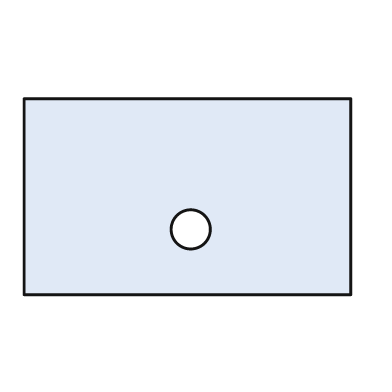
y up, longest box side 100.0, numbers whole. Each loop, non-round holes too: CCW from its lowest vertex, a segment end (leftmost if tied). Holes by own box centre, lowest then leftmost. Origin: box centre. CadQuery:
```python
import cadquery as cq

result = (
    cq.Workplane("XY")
    .moveTo(-50.0, -30.0)
    .lineTo(50.0, -30.0)
    .lineTo(50.0, 30.0)
    .lineTo(-50.0, 30.0)
    .close()
    .moveTo(1.0, -10.0)
    .circle(6.0)
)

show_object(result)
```